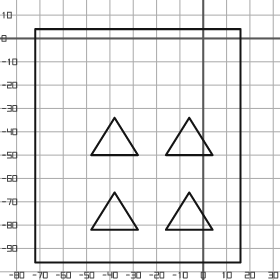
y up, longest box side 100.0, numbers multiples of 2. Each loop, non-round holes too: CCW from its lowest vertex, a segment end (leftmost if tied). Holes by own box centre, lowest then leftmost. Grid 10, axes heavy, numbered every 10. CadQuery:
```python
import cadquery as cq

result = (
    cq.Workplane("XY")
    .moveTo(-72.0, -96.0)
    .lineTo(16.0, -96.0)
    .lineTo(16.0, 4.0)
    .lineTo(-72.0, 4.0)
    .close()
    .moveTo(-48.0, -82.0)
    .lineTo(-28.0, -82.0)
    .lineTo(-38.0, -66.0)
    .close()
    .moveTo(-16.0, -82.0)
    .lineTo(4.0, -82.0)
    .lineTo(-6.0, -66.0)
    .close()
    .moveTo(-48.0, -50.0)
    .lineTo(-28.0, -50.0)
    .lineTo(-38.0, -34.0)
    .close()
    .moveTo(-16.0, -50.0)
    .lineTo(4.0, -50.0)
    .lineTo(-6.0, -34.0)
    .close()
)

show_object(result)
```